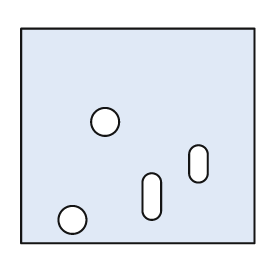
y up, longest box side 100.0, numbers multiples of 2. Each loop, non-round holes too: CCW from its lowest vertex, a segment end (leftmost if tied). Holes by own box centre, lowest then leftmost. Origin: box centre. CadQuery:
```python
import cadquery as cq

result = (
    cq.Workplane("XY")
    .moveTo(-50.0, -46.0)
    .lineTo(50.0, -46.0)
    .lineTo(50.0, 46.0)
    .lineTo(-50.0, 46.0)
    .close()
    .moveTo(-28.0, -36.0)
    .circle(6.0)
    .moveTo(2.0, -32.0)
    .threePointArc((6.0, -36.0), (10.0, -32.0))
    .lineTo(10.0, -20.0)
    .threePointArc((6.0, -16.0), (2.0, -20.0))
    .close()
    .moveTo(22.0, -16.0)
    .threePointArc((26.0, -20.0), (30.0, -16.0))
    .lineTo(30.0, -8.0)
    .threePointArc((26.0, -4.0), (22.0, -8.0))
    .close()
    .moveTo(-14.0, 6.0)
    .circle(6.0)
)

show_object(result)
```